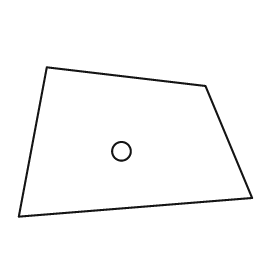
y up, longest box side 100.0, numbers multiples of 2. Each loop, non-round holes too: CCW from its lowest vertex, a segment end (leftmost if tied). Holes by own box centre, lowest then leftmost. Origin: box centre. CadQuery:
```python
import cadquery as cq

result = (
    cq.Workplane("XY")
    .moveTo(-50.0, -32.0)
    .lineTo(50.0, -24.0)
    .lineTo(30.0, 24.0)
    .lineTo(-38.0, 32.0)
    .close()
    .moveTo(-6.0, -4.0)
    .circle(4.0)
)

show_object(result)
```